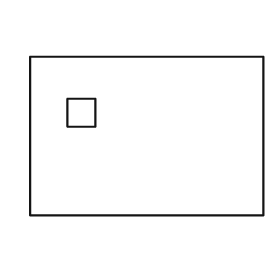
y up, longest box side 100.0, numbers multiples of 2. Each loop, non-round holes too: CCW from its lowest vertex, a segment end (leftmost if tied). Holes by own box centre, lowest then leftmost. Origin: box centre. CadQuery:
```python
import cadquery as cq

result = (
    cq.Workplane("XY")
    .moveTo(-50.0, -34.0)
    .lineTo(50.0, -34.0)
    .lineTo(50.0, 34.0)
    .lineTo(-50.0, 34.0)
    .close()
    .moveTo(-34.0, 4.0)
    .lineTo(-22.0, 4.0)
    .lineTo(-22.0, 16.0)
    .lineTo(-34.0, 16.0)
    .close()
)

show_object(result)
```